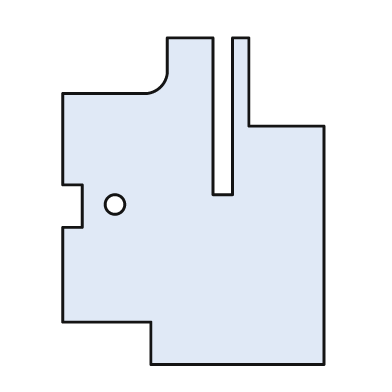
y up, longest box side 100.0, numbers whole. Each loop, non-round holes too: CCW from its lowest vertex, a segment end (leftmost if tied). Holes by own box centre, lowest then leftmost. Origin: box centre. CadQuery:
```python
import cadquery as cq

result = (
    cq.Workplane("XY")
    .moveTo(-13.0, -50.0)
    .lineTo(40.0, -50.0)
    .lineTo(40.0, 23.0)
    .lineTo(17.0, 23.0)
    .lineTo(17.0, 50.0)
    .lineTo(12.0, 50.0)
    .lineTo(12.0, 2.0)
    .lineTo(6.0, 2.0)
    .lineTo(6.0, 50.0)
    .lineTo(-8.0, 50.0)
    .lineTo(-8.0, 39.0)
    .threePointArc((-10.0, 35.0), (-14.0, 33.0))
    .lineTo(-40.0, 33.0)
    .lineTo(-40.0, 5.0)
    .lineTo(-34.0, 5.0)
    .lineTo(-34.0, -8.0)
    .lineTo(-40.0, -8.0)
    .lineTo(-40.0, -37.0)
    .lineTo(-13.0, -37.0)
    .close()
    .moveTo(-24.0, -1.0)
    .circle(3.0)
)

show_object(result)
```